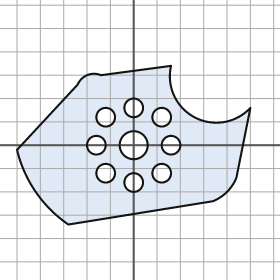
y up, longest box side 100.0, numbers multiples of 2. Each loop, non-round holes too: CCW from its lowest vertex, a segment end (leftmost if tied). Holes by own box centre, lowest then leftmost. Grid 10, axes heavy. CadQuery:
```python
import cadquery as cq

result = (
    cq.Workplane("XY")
    .moveTo(-28.0, -34.0)
    .lineTo(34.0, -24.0)
    .threePointArc((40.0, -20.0), (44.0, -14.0))
    .lineTo(50.0, 16.0)
    .threePointArc((26.0, 12.0), (16.0, 34.0))
    .lineTo(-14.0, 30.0)
    .threePointArc((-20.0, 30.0), (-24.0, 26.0))
    .lineTo(-50.0, -2.0)
    .threePointArc((-42.0, -20.0), (-28.0, -34.0))
    .close()
    .moveTo(0.0, -16.0)
    .circle(4.0)
    .moveTo(-12.0, -12.0)
    .circle(4.0)
    .moveTo(12.0, -12.0)
    .circle(4.0)
    .moveTo(-16.0, 0.0)
    .circle(4.0)
    .moveTo(0.0, 0.0)
    .circle(6.0)
    .moveTo(16.0, 0.0)
    .circle(4.0)
    .moveTo(-12.0, 12.0)
    .circle(4.0)
    .moveTo(12.0, 12.0)
    .circle(4.0)
    .moveTo(0.0, 16.0)
    .circle(4.0)
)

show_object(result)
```